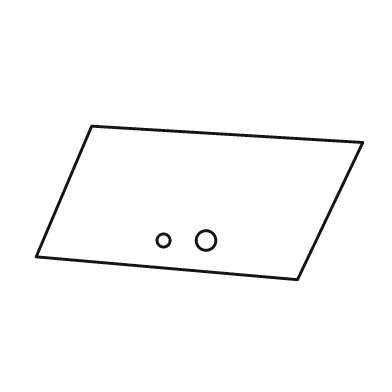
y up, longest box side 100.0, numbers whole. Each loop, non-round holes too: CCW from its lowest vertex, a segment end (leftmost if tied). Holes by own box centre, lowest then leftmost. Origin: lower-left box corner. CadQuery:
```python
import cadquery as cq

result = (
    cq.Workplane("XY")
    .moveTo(80.0, 0.0)
    .lineTo(100.0, 42.0)
    .lineTo(17.0, 47.0)
    .lineTo(0.0, 7.0)
    .close()
    .moveTo(39.0, 12.0)
    .circle(2.0)
    .moveTo(52.0, 12.0)
    .circle(3.0)
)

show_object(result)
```